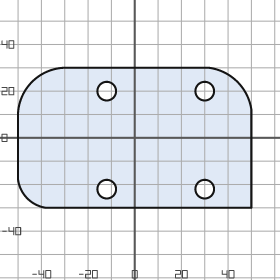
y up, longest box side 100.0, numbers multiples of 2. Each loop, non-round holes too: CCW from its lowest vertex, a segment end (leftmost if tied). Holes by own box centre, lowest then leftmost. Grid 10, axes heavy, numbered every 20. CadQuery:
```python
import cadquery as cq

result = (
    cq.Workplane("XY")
    .moveTo(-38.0, -30.0)
    .lineTo(50.0, -30.0)
    .lineTo(50.0, 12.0)
    .threePointArc((44.0, 24.0), (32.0, 30.0))
    .lineTo(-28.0, 30.0)
    .threePointArc((-44.0, 24.0), (-50.0, 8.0))
    .lineTo(-50.0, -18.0)
    .threePointArc((-46.0, -26.0), (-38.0, -30.0))
    .close()
    .moveTo(-12.0, -22.0)
    .circle(4.0)
    .moveTo(30.0, -22.0)
    .circle(4.0)
    .moveTo(-12.0, 20.0)
    .circle(4.0)
    .moveTo(30.0, 20.0)
    .circle(4.0)
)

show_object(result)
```